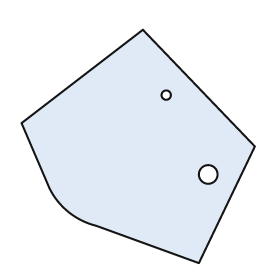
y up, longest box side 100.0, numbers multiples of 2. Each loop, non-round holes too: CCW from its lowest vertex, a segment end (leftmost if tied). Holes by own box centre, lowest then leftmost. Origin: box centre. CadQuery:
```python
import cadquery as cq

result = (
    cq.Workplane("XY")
    .moveTo(26.0, -50.0)
    .lineTo(50.0, 0.0)
    .lineTo(2.0, 50.0)
    .lineTo(-50.0, 10.0)
    .lineTo(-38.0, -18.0)
    .threePointArc((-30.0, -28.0), (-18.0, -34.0))
    .close()
    .moveTo(30.0, -12.0)
    .circle(4.0)
    .moveTo(12.0, 22.0)
    .circle(2.0)
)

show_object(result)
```